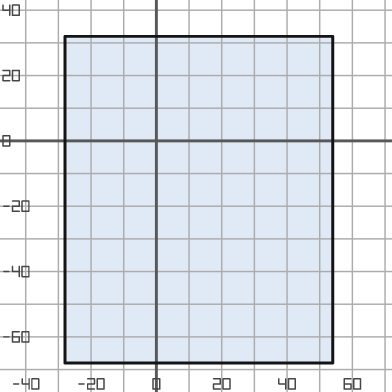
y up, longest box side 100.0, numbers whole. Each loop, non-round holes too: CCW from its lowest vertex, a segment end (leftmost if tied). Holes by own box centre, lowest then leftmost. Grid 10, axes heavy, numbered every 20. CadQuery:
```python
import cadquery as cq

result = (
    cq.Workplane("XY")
    .moveTo(-28.0, -68.0)
    .lineTo(54.0, -68.0)
    .lineTo(54.0, 32.0)
    .lineTo(-28.0, 32.0)
    .close()
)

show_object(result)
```